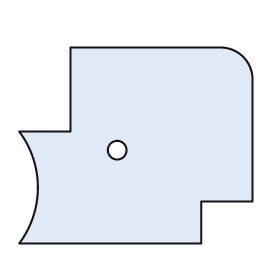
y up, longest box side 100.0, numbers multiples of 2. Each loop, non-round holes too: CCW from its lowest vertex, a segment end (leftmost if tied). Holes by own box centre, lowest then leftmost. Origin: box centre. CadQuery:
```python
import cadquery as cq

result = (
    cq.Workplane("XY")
    .moveTo(-50.0, -42.0)
    .lineTo(28.0, -42.0)
    .lineTo(28.0, -24.0)
    .lineTo(50.0, -24.0)
    .lineTo(50.0, 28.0)
    .threePointArc((46.0, 38.0), (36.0, 42.0))
    .lineTo(-28.0, 42.0)
    .lineTo(-28.0, 6.0)
    .lineTo(-50.0, 6.0)
    .threePointArc((-42.0, -18.0), (-50.0, -42.0))
    .close()
    .moveTo(-8.0, -2.0)
    .circle(4.0)
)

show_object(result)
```